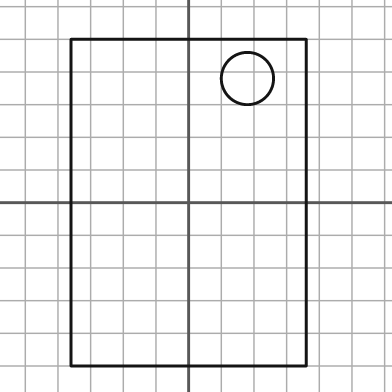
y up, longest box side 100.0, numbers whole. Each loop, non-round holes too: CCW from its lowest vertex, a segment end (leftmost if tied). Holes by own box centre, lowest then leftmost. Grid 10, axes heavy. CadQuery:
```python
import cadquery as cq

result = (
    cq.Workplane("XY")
    .moveTo(-36.0, -50.0)
    .lineTo(36.0, -50.0)
    .lineTo(36.0, 50.0)
    .lineTo(-36.0, 50.0)
    .close()
    .moveTo(18.0, 38.0)
    .circle(8.0)
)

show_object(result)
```